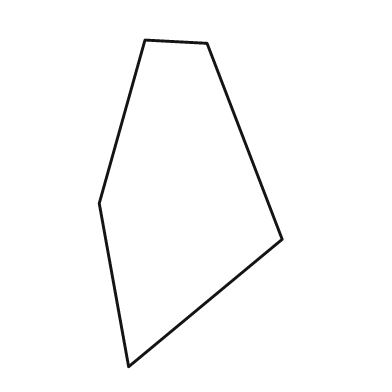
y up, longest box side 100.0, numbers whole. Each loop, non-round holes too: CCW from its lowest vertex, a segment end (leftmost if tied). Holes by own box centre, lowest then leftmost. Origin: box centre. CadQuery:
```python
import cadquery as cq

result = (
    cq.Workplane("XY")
    .moveTo(-19.0, -50.0)
    .lineTo(28.0, -11.0)
    .lineTo(5.0, 49.0)
    .lineTo(-14.0, 50.0)
    .lineTo(-28.0, 0.0)
    .close()
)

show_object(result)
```